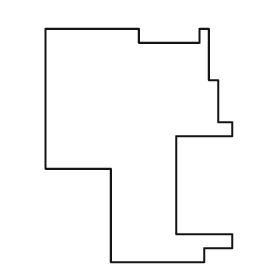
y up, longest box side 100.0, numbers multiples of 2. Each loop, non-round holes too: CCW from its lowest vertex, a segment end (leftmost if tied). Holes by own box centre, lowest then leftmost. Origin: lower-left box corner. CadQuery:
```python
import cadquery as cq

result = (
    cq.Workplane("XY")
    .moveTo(28.0, 0.0)
    .lineTo(68.0, 0.0)
    .lineTo(68.0, 6.0)
    .lineTo(80.0, 6.0)
    .lineTo(80.0, 12.0)
    .lineTo(56.0, 12.0)
    .lineTo(56.0, 54.0)
    .lineTo(80.0, 54.0)
    .lineTo(80.0, 60.0)
    .lineTo(74.0, 60.0)
    .lineTo(74.0, 78.0)
    .lineTo(70.0, 78.0)
    .lineTo(70.0, 100.0)
    .lineTo(66.0, 100.0)
    .lineTo(66.0, 94.0)
    .lineTo(40.0, 94.0)
    .lineTo(40.0, 100.0)
    .lineTo(0.0, 100.0)
    .lineTo(0.0, 40.0)
    .lineTo(28.0, 40.0)
    .close()
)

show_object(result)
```